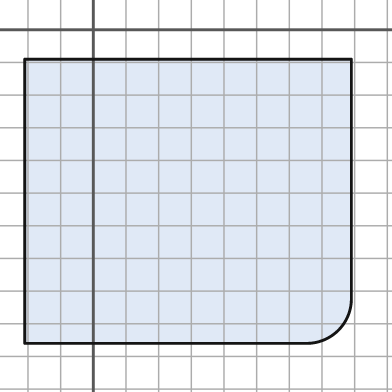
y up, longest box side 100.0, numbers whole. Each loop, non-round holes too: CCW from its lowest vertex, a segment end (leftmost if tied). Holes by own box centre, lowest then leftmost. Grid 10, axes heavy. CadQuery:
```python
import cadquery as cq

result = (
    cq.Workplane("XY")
    .moveTo(-21.0, -96.0)
    .lineTo(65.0, -96.0)
    .threePointArc((75.0, -92.0), (79.0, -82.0))
    .lineTo(79.0, -9.0)
    .lineTo(-21.0, -9.0)
    .close()
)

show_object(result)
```